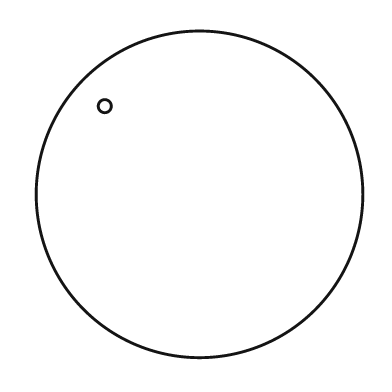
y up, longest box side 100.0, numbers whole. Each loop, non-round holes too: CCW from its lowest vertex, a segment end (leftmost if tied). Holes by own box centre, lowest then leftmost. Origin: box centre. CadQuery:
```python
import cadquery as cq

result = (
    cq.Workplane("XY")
    .moveTo(0.0, 0.0)
    .circle(50.0)
    .moveTo(-29.0, 27.0)
    .circle(2.0)
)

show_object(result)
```